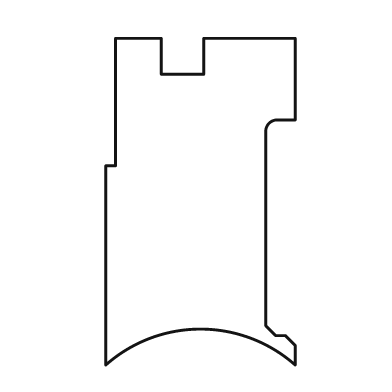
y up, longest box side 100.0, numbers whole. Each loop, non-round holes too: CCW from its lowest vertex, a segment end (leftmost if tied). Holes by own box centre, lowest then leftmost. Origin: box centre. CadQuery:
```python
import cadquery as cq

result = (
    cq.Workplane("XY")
    .moveTo(-29.0, -50.0)
    .threePointArc((0.0, -39.0), (29.0, -50.0))
    .lineTo(29.0, -44.0)
    .lineTo(26.0, -41.0)
    .lineTo(23.0, -41.0)
    .lineTo(20.0, -38.0)
    .lineTo(20.0, 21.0)
    .threePointArc((21.0, 24.0), (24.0, 25.0))
    .lineTo(29.0, 25.0)
    .lineTo(29.0, 50.0)
    .lineTo(1.0, 50.0)
    .lineTo(1.0, 39.0)
    .lineTo(-12.0, 39.0)
    .lineTo(-12.0, 50.0)
    .lineTo(-26.0, 50.0)
    .lineTo(-26.0, 11.0)
    .lineTo(-29.0, 11.0)
    .close()
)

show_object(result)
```